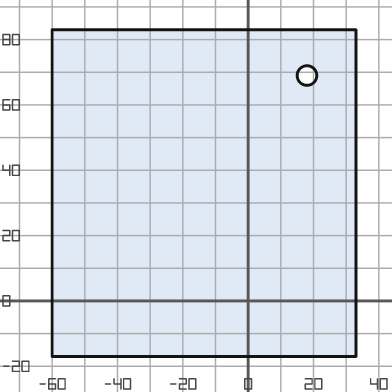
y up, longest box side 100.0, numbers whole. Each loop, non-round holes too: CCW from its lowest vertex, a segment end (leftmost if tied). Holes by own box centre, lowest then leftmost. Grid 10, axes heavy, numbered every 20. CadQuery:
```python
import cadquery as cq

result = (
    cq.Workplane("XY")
    .moveTo(-60.0, -17.0)
    .lineTo(33.0, -17.0)
    .lineTo(33.0, 83.0)
    .lineTo(-60.0, 83.0)
    .close()
    .moveTo(18.0, 69.0)
    .circle(3.0)
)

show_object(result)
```